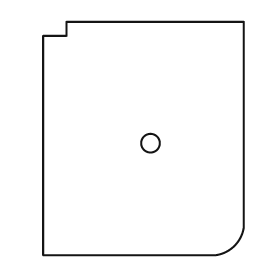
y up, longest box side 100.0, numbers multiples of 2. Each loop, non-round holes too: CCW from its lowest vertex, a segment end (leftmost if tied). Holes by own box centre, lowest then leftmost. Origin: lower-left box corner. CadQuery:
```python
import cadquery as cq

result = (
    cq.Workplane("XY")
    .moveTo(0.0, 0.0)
    .lineTo(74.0, 0.0)
    .threePointArc((82.0, 4.0), (86.0, 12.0))
    .lineTo(86.0, 100.0)
    .lineTo(10.0, 100.0)
    .lineTo(10.0, 94.0)
    .lineTo(0.0, 94.0)
    .close()
    .moveTo(46.0, 48.0)
    .circle(4.0)
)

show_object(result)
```